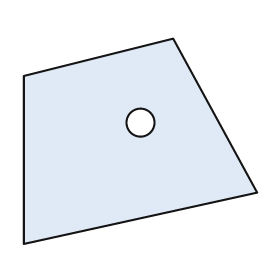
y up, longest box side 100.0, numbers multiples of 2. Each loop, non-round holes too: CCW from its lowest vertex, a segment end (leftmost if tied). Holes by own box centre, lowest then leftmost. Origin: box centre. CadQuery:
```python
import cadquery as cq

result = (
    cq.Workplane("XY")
    .moveTo(-50.0, -44.0)
    .lineTo(50.0, -22.0)
    .lineTo(14.0, 44.0)
    .lineTo(-50.0, 28.0)
    .close()
    .moveTo(0.0, 8.0)
    .circle(6.0)
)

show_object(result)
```